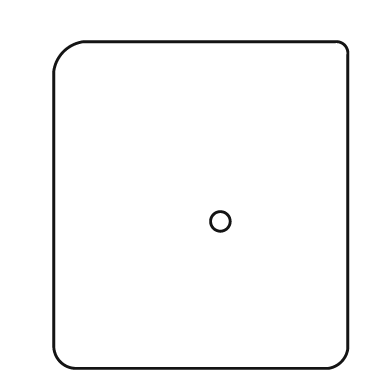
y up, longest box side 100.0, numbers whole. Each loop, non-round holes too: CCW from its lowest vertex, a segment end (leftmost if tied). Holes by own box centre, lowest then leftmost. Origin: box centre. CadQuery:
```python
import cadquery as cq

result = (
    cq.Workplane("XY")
    .moveTo(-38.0, -50.0)
    .lineTo(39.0, -50.0)
    .threePointArc((43.0, -48.0), (45.0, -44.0))
    .lineTo(45.0, 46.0)
    .threePointArc((44.0, 49.0), (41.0, 50.0))
    .lineTo(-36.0, 50.0)
    .threePointArc((-42.0, 47.0), (-45.0, 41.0))
    .lineTo(-45.0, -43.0)
    .threePointArc((-43.0, -48.0), (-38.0, -50.0))
    .close()
    .moveTo(6.0, -5.0)
    .circle(3.0)
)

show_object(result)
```